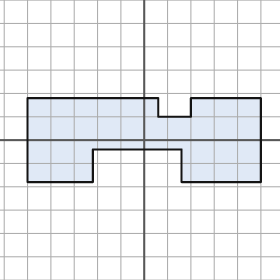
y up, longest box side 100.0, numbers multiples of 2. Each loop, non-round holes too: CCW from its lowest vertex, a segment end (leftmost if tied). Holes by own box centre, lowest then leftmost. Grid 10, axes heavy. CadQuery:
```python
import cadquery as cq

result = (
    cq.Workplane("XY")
    .moveTo(-50.0, -18.0)
    .lineTo(-22.0, -18.0)
    .lineTo(-22.0, -4.0)
    .lineTo(16.0, -4.0)
    .lineTo(16.0, -18.0)
    .lineTo(50.0, -18.0)
    .lineTo(50.0, 18.0)
    .lineTo(20.0, 18.0)
    .lineTo(20.0, 10.0)
    .lineTo(6.0, 10.0)
    .lineTo(6.0, 18.0)
    .lineTo(-50.0, 18.0)
    .close()
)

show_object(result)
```